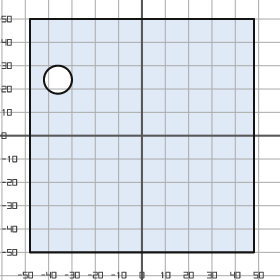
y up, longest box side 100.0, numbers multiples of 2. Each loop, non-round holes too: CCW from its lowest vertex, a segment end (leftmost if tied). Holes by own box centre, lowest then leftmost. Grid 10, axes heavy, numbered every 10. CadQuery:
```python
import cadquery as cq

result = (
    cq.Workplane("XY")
    .moveTo(-48.0, -50.0)
    .lineTo(48.0, -50.0)
    .lineTo(48.0, 50.0)
    .lineTo(-48.0, 50.0)
    .close()
    .moveTo(-36.0, 24.0)
    .circle(6.0)
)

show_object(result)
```